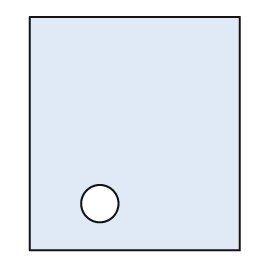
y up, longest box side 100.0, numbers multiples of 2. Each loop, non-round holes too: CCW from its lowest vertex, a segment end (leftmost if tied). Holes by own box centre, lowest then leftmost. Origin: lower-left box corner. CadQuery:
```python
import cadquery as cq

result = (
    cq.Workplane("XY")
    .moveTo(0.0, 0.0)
    .lineTo(90.0, 0.0)
    .lineTo(90.0, 100.0)
    .lineTo(0.0, 100.0)
    .close()
    .moveTo(30.0, 20.0)
    .circle(8.0)
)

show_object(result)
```